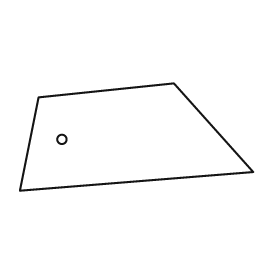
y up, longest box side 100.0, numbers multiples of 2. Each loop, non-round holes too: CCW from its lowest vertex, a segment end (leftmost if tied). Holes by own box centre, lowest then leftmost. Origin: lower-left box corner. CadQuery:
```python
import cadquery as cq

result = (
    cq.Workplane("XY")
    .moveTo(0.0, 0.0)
    .lineTo(100.0, 8.0)
    .lineTo(66.0, 46.0)
    .lineTo(8.0, 40.0)
    .close()
    .moveTo(18.0, 22.0)
    .circle(2.0)
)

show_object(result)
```